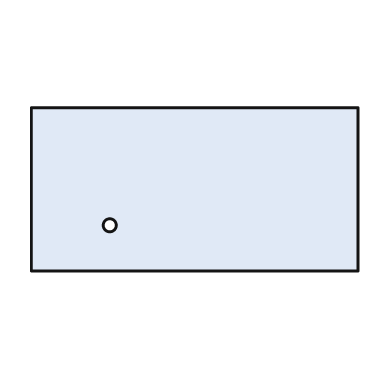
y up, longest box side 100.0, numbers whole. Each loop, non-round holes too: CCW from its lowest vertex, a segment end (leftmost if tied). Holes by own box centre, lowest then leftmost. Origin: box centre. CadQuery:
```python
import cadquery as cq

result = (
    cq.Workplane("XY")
    .moveTo(-50.0, -25.0)
    .lineTo(50.0, -25.0)
    .lineTo(50.0, 25.0)
    .lineTo(-50.0, 25.0)
    .close()
    .moveTo(-26.0, -11.0)
    .circle(2.0)
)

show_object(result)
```